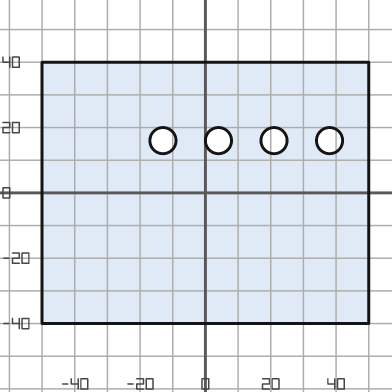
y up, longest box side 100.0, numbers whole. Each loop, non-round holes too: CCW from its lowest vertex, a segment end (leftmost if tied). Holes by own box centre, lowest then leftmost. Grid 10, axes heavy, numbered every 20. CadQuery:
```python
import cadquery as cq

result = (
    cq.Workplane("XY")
    .moveTo(-50.0, -40.0)
    .lineTo(50.0, -40.0)
    .lineTo(50.0, 40.0)
    .lineTo(-50.0, 40.0)
    .close()
    .moveTo(-13.0, 16.0)
    .circle(4.0)
    .moveTo(4.0, 16.0)
    .circle(4.0)
    .moveTo(21.0, 16.0)
    .circle(4.0)
    .moveTo(38.0, 16.0)
    .circle(4.0)
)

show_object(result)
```